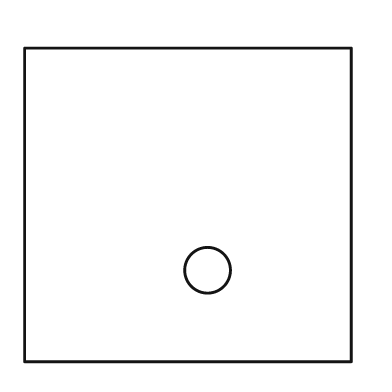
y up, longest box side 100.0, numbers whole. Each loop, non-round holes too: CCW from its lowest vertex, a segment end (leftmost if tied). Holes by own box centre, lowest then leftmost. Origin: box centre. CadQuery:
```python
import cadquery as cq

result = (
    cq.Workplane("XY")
    .moveTo(-50.0, -48.0)
    .lineTo(50.0, -48.0)
    .lineTo(50.0, 48.0)
    .lineTo(-50.0, 48.0)
    .close()
    .moveTo(6.0, -20.0)
    .circle(7.0)
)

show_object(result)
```